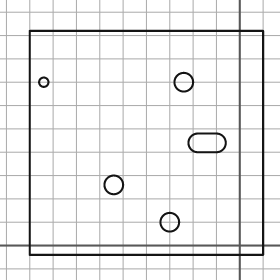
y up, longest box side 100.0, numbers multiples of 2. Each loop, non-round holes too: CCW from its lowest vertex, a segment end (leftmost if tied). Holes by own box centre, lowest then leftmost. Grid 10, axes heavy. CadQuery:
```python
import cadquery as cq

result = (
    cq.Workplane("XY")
    .moveTo(-90.0, -4.0)
    .lineTo(10.0, -4.0)
    .lineTo(10.0, 92.0)
    .lineTo(-90.0, 92.0)
    .close()
    .moveTo(-30.0, 10.0)
    .circle(4.0)
    .moveTo(-54.0, 26.0)
    .circle(4.0)
    .moveTo(-18.0, 40.0)
    .lineTo(-10.0, 40.0)
    .threePointArc((-6.0, 44.0), (-10.0, 48.0))
    .lineTo(-18.0, 48.0)
    .threePointArc((-22.0, 44.0), (-18.0, 40.0))
    .close()
    .moveTo(-84.0, 70.0)
    .circle(2.0)
    .moveTo(-24.0, 70.0)
    .circle(4.0)
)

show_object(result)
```